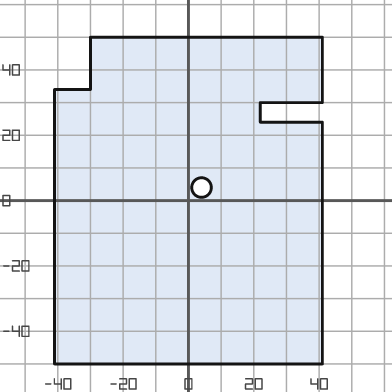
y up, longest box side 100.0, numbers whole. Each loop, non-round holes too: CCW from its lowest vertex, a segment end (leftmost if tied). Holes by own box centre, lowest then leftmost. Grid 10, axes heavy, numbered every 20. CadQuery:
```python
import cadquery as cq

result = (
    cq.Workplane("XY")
    .moveTo(-41.0, -50.0)
    .lineTo(41.0, -50.0)
    .lineTo(41.0, 24.0)
    .lineTo(22.0, 24.0)
    .lineTo(22.0, 30.0)
    .lineTo(41.0, 30.0)
    .lineTo(41.0, 50.0)
    .lineTo(-30.0, 50.0)
    .lineTo(-30.0, 34.0)
    .lineTo(-41.0, 34.0)
    .close()
    .moveTo(4.0, 4.0)
    .circle(3.0)
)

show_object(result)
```